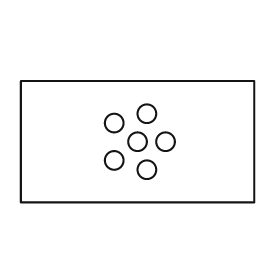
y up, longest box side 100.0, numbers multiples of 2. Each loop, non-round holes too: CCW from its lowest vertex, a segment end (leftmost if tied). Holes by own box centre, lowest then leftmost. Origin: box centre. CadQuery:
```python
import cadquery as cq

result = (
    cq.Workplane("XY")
    .moveTo(-50.0, -26.0)
    .lineTo(50.0, -26.0)
    .lineTo(50.0, 26.0)
    .lineTo(-50.0, 26.0)
    .close()
    .moveTo(4.0, -12.0)
    .circle(4.0)
    .moveTo(-10.0, -8.0)
    .circle(4.0)
    .moveTo(0.0, 0.0)
    .circle(4.0)
    .moveTo(12.0, 0.0)
    .circle(4.0)
    .moveTo(-10.0, 8.0)
    .circle(4.0)
    .moveTo(4.0, 12.0)
    .circle(4.0)
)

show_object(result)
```